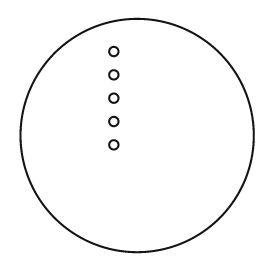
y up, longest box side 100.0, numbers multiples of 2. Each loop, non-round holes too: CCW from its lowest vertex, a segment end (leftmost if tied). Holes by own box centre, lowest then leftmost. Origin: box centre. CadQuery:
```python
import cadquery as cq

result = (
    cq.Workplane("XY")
    .moveTo(0.0, 0.0)
    .circle(50.0)
    .moveTo(-10.0, -4.0)
    .circle(2.0)
    .moveTo(-10.0, 6.0)
    .circle(2.0)
    .moveTo(-10.0, 16.0)
    .circle(2.0)
    .moveTo(-10.0, 26.0)
    .circle(2.0)
    .moveTo(-10.0, 36.0)
    .circle(2.0)
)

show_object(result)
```